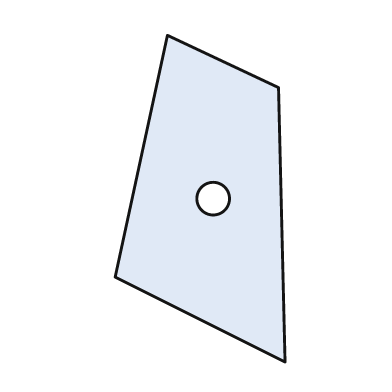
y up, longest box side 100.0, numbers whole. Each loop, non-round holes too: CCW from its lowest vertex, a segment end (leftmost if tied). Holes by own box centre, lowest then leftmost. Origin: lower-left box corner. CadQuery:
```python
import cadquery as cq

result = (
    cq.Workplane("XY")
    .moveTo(52.0, 0.0)
    .lineTo(50.0, 84.0)
    .lineTo(16.0, 100.0)
    .lineTo(0.0, 26.0)
    .close()
    .moveTo(30.0, 50.0)
    .circle(5.0)
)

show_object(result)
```